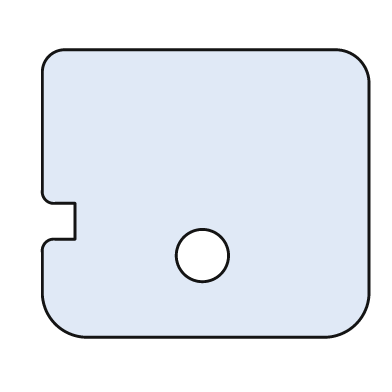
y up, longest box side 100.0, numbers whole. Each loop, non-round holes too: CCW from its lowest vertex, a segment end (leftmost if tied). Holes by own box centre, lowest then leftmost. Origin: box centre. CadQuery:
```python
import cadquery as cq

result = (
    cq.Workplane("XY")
    .moveTo(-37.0, -44.0)
    .lineTo(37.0, -44.0)
    .threePointArc((46.0, -40.0), (50.0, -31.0))
    .lineTo(50.0, 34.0)
    .threePointArc((47.0, 41.0), (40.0, 44.0))
    .lineTo(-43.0, 44.0)
    .threePointArc((-48.0, 42.0), (-50.0, 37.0))
    .lineTo(-50.0, 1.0)
    .threePointArc((-49.0, -2.0), (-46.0, -3.0))
    .lineTo(-40.0, -3.0)
    .lineTo(-40.0, -14.0)
    .lineTo(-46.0, -14.0)
    .threePointArc((-49.0, -15.0), (-50.0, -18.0))
    .lineTo(-50.0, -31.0)
    .threePointArc((-46.0, -40.0), (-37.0, -44.0))
    .close()
    .moveTo(-1.0, -19.0)
    .circle(8.0)
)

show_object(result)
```